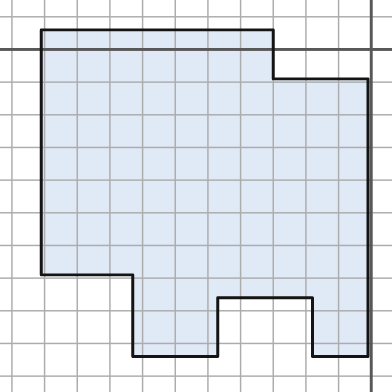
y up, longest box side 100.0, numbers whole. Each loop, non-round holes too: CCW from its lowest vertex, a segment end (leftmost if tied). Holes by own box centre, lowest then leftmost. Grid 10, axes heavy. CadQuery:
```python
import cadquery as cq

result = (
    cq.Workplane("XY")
    .moveTo(-73.0, -94.0)
    .lineTo(-47.0, -94.0)
    .lineTo(-47.0, -76.0)
    .lineTo(-18.0, -76.0)
    .lineTo(-18.0, -94.0)
    .lineTo(-1.0, -94.0)
    .lineTo(-1.0, -9.0)
    .lineTo(-30.0, -9.0)
    .lineTo(-30.0, 6.0)
    .lineTo(-101.0, 6.0)
    .lineTo(-101.0, -69.0)
    .lineTo(-73.0, -69.0)
    .close()
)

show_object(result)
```